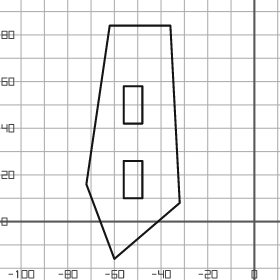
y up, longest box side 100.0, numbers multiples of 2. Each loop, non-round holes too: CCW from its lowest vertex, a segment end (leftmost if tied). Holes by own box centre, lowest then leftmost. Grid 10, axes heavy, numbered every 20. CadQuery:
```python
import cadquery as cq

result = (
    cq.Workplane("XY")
    .moveTo(-60.0, -16.0)
    .lineTo(-32.0, 8.0)
    .lineTo(-36.0, 84.0)
    .lineTo(-62.0, 84.0)
    .lineTo(-72.0, 16.0)
    .close()
    .moveTo(-56.0, 10.0)
    .lineTo(-48.0, 10.0)
    .lineTo(-48.0, 26.0)
    .lineTo(-56.0, 26.0)
    .close()
    .moveTo(-56.0, 42.0)
    .lineTo(-48.0, 42.0)
    .lineTo(-48.0, 58.0)
    .lineTo(-56.0, 58.0)
    .close()
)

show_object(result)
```